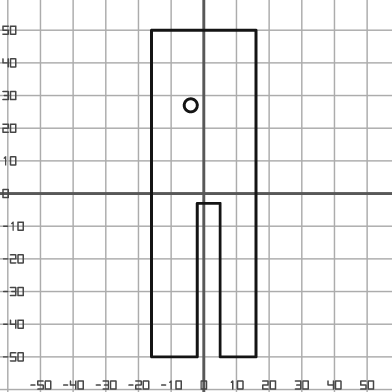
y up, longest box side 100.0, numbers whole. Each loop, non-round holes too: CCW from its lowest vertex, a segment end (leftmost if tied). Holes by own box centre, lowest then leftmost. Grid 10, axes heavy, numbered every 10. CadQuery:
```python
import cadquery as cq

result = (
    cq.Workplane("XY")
    .moveTo(-16.0, -50.0)
    .lineTo(-2.0, -50.0)
    .lineTo(-2.0, -3.0)
    .lineTo(5.0, -3.0)
    .lineTo(5.0, -50.0)
    .lineTo(16.0, -50.0)
    .lineTo(16.0, 50.0)
    .lineTo(-16.0, 50.0)
    .close()
    .moveTo(-4.0, 27.0)
    .circle(2.0)
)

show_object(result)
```